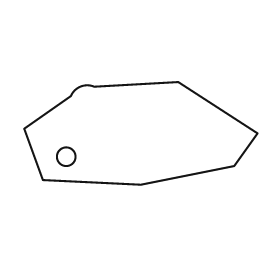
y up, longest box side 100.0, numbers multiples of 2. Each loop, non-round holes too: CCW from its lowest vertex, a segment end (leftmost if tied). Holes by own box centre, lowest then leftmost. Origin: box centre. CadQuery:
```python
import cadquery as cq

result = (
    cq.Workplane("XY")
    .moveTo(0.0, -22.0)
    .lineTo(40.0, -14.0)
    .lineTo(50.0, 0.0)
    .lineTo(16.0, 22.0)
    .lineTo(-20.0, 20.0)
    .threePointArc((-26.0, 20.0), (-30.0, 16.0))
    .lineTo(-50.0, 2.0)
    .lineTo(-42.0, -20.0)
    .close()
    .moveTo(-32.0, -10.0)
    .circle(4.0)
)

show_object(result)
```